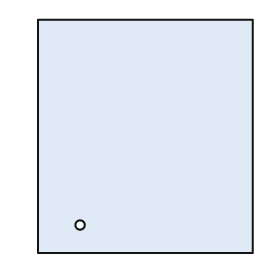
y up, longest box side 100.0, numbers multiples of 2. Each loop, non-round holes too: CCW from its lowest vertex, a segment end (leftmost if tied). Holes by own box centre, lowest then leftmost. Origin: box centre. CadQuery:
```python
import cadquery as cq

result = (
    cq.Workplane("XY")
    .moveTo(-46.0, -50.0)
    .lineTo(46.0, -50.0)
    .lineTo(46.0, 50.0)
    .lineTo(-46.0, 50.0)
    .close()
    .moveTo(-28.0, -38.0)
    .circle(2.0)
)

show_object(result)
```